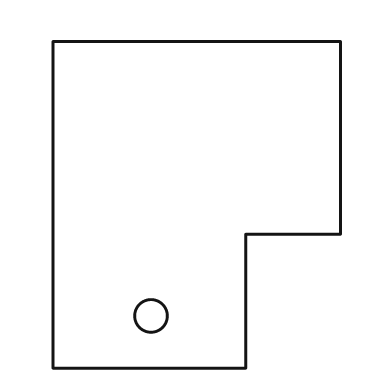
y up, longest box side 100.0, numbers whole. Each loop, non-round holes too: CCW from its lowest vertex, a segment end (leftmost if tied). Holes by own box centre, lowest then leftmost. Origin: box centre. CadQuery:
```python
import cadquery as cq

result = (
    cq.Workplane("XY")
    .moveTo(-44.0, -50.0)
    .lineTo(15.0, -50.0)
    .lineTo(15.0, -9.0)
    .lineTo(44.0, -9.0)
    .lineTo(44.0, 50.0)
    .lineTo(-44.0, 50.0)
    .close()
    .moveTo(-14.0, -34.0)
    .circle(5.0)
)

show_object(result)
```